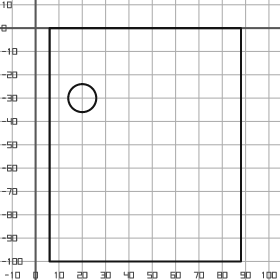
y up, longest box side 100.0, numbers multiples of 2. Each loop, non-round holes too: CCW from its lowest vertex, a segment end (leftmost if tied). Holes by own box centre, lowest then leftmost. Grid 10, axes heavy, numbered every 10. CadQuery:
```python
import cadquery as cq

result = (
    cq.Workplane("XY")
    .moveTo(6.0, -100.0)
    .lineTo(88.0, -100.0)
    .lineTo(88.0, 0.0)
    .lineTo(6.0, 0.0)
    .close()
    .moveTo(20.0, -30.0)
    .circle(6.0)
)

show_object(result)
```